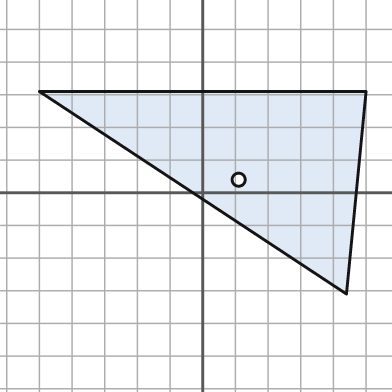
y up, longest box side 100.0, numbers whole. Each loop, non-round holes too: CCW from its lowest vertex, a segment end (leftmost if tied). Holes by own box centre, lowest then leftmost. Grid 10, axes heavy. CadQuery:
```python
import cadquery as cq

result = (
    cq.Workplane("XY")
    .moveTo(44.0, -31.0)
    .lineTo(50.0, 31.0)
    .lineTo(-50.0, 31.0)
    .close()
    .moveTo(11.0, 4.0)
    .circle(2.0)
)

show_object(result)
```